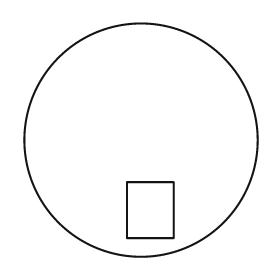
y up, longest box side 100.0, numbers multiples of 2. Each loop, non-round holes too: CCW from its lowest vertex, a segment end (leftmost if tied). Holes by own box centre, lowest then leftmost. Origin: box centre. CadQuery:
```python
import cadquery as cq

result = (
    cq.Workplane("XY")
    .moveTo(0.0, 0.0)
    .circle(50.0)
    .moveTo(-6.0, -42.0)
    .lineTo(14.0, -42.0)
    .lineTo(14.0, -18.0)
    .lineTo(-6.0, -18.0)
    .close()
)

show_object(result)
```